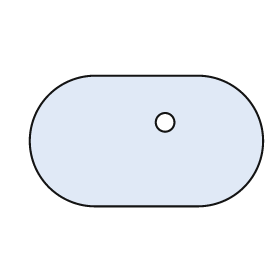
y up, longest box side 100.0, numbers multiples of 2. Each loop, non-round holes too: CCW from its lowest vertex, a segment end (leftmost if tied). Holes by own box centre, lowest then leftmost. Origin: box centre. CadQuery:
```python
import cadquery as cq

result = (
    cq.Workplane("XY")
    .moveTo(-22.0, -28.0)
    .lineTo(22.0, -28.0)
    .threePointArc((50.0, 0.0), (22.0, 28.0))
    .lineTo(-22.0, 28.0)
    .threePointArc((-50.0, 0.0), (-22.0, -28.0))
    .close()
    .moveTo(8.0, 8.0)
    .circle(4.0)
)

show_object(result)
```